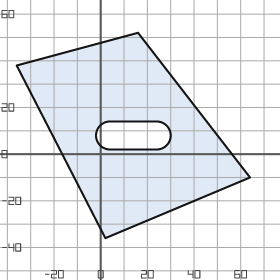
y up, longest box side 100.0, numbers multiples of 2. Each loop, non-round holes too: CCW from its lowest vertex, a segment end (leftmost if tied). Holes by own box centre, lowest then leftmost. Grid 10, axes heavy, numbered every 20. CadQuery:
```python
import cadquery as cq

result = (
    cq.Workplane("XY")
    .moveTo(2.0, -36.0)
    .lineTo(64.0, -10.0)
    .lineTo(16.0, 52.0)
    .lineTo(-36.0, 38.0)
    .close()
    .moveTo(4.0, 2.0)
    .lineTo(24.0, 2.0)
    .threePointArc((30.0, 8.0), (24.0, 14.0))
    .lineTo(4.0, 14.0)
    .threePointArc((-2.0, 8.0), (4.0, 2.0))
    .close()
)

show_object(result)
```